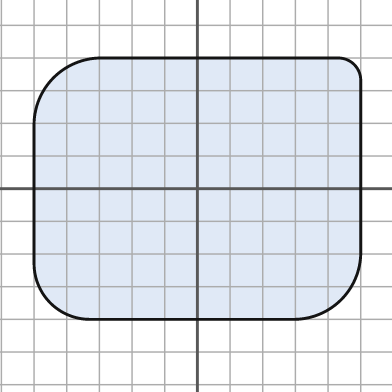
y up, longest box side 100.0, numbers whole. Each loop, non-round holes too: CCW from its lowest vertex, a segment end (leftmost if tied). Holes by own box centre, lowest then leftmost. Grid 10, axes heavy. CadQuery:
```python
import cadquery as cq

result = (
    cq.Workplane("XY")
    .moveTo(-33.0, -40.0)
    .lineTo(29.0, -40.0)
    .threePointArc((44.0, -34.0), (50.0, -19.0))
    .lineTo(50.0, 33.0)
    .threePointArc((48.0, 38.0), (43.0, 40.0))
    .lineTo(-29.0, 40.0)
    .threePointArc((-44.0, 34.0), (-50.0, 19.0))
    .lineTo(-50.0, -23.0)
    .threePointArc((-45.0, -35.0), (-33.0, -40.0))
    .close()
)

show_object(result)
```